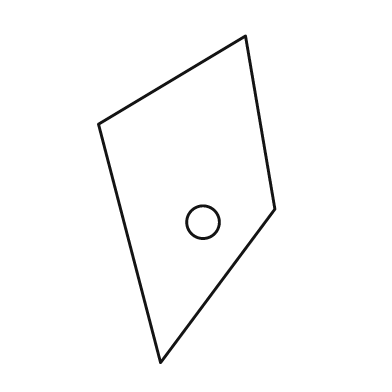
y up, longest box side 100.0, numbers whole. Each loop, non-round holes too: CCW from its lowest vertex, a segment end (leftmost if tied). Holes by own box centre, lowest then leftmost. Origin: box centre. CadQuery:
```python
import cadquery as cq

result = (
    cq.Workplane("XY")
    .moveTo(-8.0, -50.0)
    .lineTo(27.0, -3.0)
    .lineTo(18.0, 50.0)
    .lineTo(-27.0, 23.0)
    .close()
    .moveTo(5.0, -7.0)
    .circle(5.0)
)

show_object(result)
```